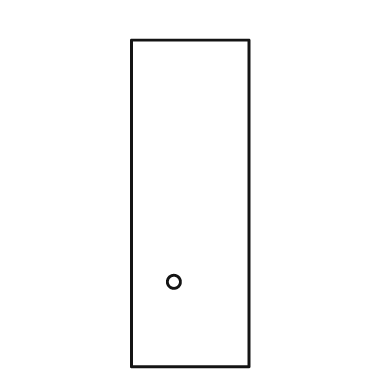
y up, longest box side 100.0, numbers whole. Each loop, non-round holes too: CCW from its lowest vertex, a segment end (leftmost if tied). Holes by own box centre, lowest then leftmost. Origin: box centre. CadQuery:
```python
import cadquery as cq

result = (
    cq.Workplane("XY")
    .moveTo(-18.0, -50.0)
    .lineTo(18.0, -50.0)
    .lineTo(18.0, 50.0)
    .lineTo(-18.0, 50.0)
    .close()
    .moveTo(-5.0, -24.0)
    .circle(2.0)
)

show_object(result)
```